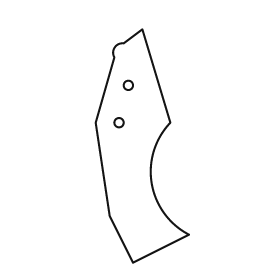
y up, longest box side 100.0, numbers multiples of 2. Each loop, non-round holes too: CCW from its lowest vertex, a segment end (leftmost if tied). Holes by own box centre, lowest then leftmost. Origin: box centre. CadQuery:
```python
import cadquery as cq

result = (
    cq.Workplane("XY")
    .moveTo(-4.0, -50.0)
    .lineTo(20.0, -38.0)
    .threePointArc((4.0, -16.0), (12.0, 10.0))
    .lineTo(0.0, 50.0)
    .lineTo(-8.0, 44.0)
    .threePointArc((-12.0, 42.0), (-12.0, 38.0))
    .lineTo(-20.0, 10.0)
    .lineTo(-14.0, -30.0)
    .close()
    .moveTo(-10.0, 10.0)
    .circle(2.0)
    .moveTo(-6.0, 26.0)
    .circle(2.0)
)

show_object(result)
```